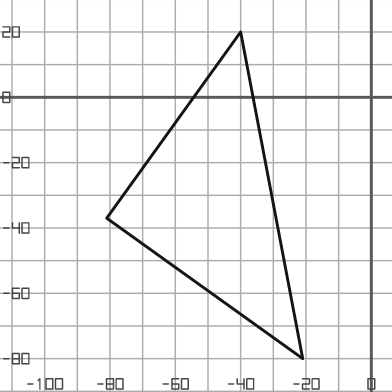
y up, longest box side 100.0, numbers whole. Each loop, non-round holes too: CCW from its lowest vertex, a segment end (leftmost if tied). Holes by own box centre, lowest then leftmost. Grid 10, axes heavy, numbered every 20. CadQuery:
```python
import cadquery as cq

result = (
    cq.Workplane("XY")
    .moveTo(-21.0, -80.0)
    .lineTo(-40.0, 20.0)
    .lineTo(-81.0, -37.0)
    .close()
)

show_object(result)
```